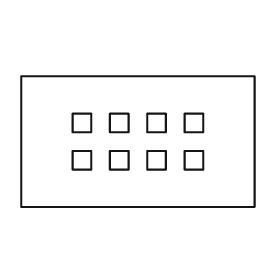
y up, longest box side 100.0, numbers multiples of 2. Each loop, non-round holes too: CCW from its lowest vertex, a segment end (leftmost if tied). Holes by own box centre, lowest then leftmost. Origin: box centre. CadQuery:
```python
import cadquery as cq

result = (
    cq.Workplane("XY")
    .moveTo(-50.0, -28.0)
    .lineTo(50.0, -28.0)
    .lineTo(50.0, 28.0)
    .lineTo(-50.0, 28.0)
    .close()
    .moveTo(-28.0, -12.0)
    .lineTo(-20.0, -12.0)
    .lineTo(-20.0, -4.0)
    .lineTo(-28.0, -4.0)
    .close()
    .moveTo(-12.0, -12.0)
    .lineTo(-4.0, -12.0)
    .lineTo(-4.0, -4.0)
    .lineTo(-12.0, -4.0)
    .close()
    .moveTo(4.0, -12.0)
    .lineTo(12.0, -12.0)
    .lineTo(12.0, -4.0)
    .lineTo(4.0, -4.0)
    .close()
    .moveTo(20.0, -12.0)
    .lineTo(28.0, -12.0)
    .lineTo(28.0, -4.0)
    .lineTo(20.0, -4.0)
    .close()
    .moveTo(-28.0, 4.0)
    .lineTo(-20.0, 4.0)
    .lineTo(-20.0, 12.0)
    .lineTo(-28.0, 12.0)
    .close()
    .moveTo(-12.0, 4.0)
    .lineTo(-4.0, 4.0)
    .lineTo(-4.0, 12.0)
    .lineTo(-12.0, 12.0)
    .close()
    .moveTo(4.0, 4.0)
    .lineTo(12.0, 4.0)
    .lineTo(12.0, 12.0)
    .lineTo(4.0, 12.0)
    .close()
    .moveTo(20.0, 4.0)
    .lineTo(28.0, 4.0)
    .lineTo(28.0, 12.0)
    .lineTo(20.0, 12.0)
    .close()
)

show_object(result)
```